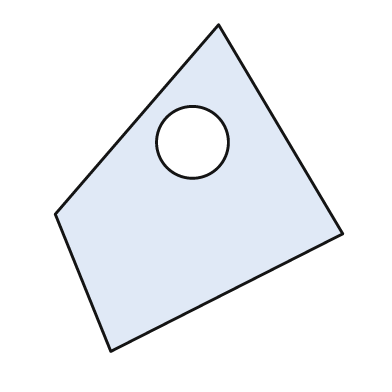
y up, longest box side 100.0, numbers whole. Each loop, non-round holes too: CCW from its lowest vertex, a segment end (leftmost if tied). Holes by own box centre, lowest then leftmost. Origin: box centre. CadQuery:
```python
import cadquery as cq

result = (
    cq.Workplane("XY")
    .moveTo(-27.0, -50.0)
    .lineTo(44.0, -14.0)
    .lineTo(6.0, 50.0)
    .lineTo(-44.0, -8.0)
    .close()
    .moveTo(-2.0, 14.0)
    .circle(11.0)
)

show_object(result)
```